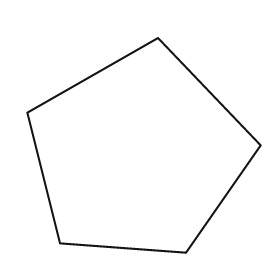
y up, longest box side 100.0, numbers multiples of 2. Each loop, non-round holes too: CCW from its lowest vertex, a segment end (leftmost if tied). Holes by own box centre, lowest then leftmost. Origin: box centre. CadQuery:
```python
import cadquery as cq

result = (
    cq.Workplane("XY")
    .moveTo(18.0, -46.0)
    .lineTo(50.0, 0.0)
    .lineTo(6.0, 46.0)
    .lineTo(-50.0, 14.0)
    .lineTo(-36.0, -42.0)
    .close()
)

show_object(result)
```